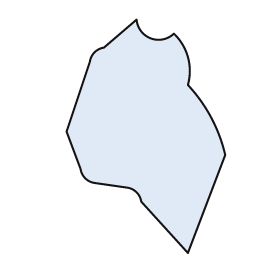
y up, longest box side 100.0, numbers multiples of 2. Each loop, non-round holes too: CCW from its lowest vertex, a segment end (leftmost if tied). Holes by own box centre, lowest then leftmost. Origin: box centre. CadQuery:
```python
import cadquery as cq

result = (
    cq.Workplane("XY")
    .moveTo(18.0, -50.0)
    .lineTo(34.0, -8.0)
    .threePointArc((28.0, 8.0), (18.0, 22.0))
    .threePointArc((18.0, 34.0), (12.0, 44.0))
    .threePointArc((2.0, 42.0), (-4.0, 50.0))
    .lineTo(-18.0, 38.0)
    .threePointArc((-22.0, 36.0), (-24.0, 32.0))
    .lineTo(-34.0, 2.0)
    .lineTo(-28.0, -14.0)
    .threePointArc((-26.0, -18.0), (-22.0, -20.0))
    .lineTo(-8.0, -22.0)
    .threePointArc((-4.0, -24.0), (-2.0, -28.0))
    .close()
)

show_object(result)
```